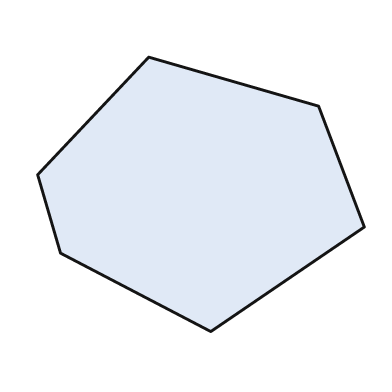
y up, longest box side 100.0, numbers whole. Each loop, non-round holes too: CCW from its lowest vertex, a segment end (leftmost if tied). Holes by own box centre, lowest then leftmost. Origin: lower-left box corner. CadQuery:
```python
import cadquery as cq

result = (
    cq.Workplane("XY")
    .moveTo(53.0, 0.0)
    .lineTo(100.0, 32.0)
    .lineTo(86.0, 69.0)
    .lineTo(34.0, 84.0)
    .lineTo(0.0, 48.0)
    .lineTo(7.0, 24.0)
    .close()
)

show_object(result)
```